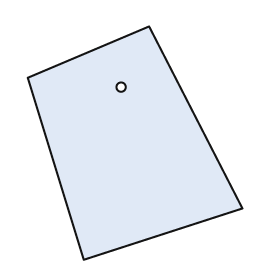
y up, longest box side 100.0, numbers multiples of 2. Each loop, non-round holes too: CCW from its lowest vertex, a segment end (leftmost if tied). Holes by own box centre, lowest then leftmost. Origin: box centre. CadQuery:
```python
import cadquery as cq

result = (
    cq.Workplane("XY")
    .moveTo(-22.0, -50.0)
    .lineTo(46.0, -28.0)
    .lineTo(6.0, 50.0)
    .lineTo(-46.0, 28.0)
    .close()
    .moveTo(-6.0, 24.0)
    .circle(2.0)
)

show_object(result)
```